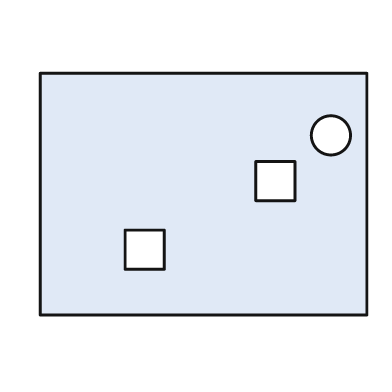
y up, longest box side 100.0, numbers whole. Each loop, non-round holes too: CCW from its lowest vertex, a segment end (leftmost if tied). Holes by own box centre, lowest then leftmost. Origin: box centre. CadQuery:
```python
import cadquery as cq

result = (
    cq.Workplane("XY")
    .moveTo(-50.0, -37.0)
    .lineTo(50.0, -37.0)
    .lineTo(50.0, 37.0)
    .lineTo(-50.0, 37.0)
    .close()
    .moveTo(-24.0, -23.0)
    .lineTo(-12.0, -23.0)
    .lineTo(-12.0, -11.0)
    .lineTo(-24.0, -11.0)
    .close()
    .moveTo(16.0, -2.0)
    .lineTo(28.0, -2.0)
    .lineTo(28.0, 10.0)
    .lineTo(16.0, 10.0)
    .close()
    .moveTo(39.0, 18.0)
    .circle(6.0)
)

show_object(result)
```